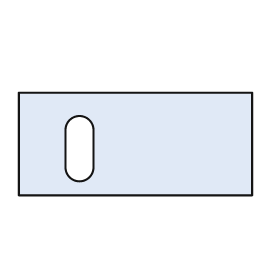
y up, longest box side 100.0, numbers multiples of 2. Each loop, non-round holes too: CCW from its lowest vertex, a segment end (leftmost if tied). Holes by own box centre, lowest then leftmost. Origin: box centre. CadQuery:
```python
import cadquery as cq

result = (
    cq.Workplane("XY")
    .moveTo(-50.0, -22.0)
    .lineTo(50.0, -22.0)
    .lineTo(50.0, 22.0)
    .lineTo(-50.0, 22.0)
    .close()
    .moveTo(-30.0, -10.0)
    .threePointArc((-24.0, -16.0), (-18.0, -10.0))
    .lineTo(-18.0, 6.0)
    .threePointArc((-24.0, 12.0), (-30.0, 6.0))
    .close()
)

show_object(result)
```